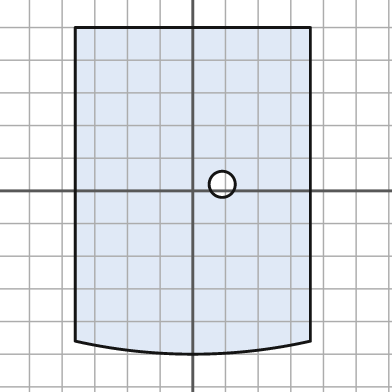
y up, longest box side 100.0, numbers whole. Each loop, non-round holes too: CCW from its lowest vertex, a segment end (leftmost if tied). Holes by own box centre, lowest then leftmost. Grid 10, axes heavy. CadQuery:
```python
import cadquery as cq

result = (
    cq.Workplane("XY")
    .moveTo(-36.0, -46.0)
    .threePointArc((0.0, -50.0), (36.0, -46.0))
    .lineTo(36.0, 50.0)
    .lineTo(-36.0, 50.0)
    .close()
    .moveTo(9.0, 2.0)
    .circle(4.0)
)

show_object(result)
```